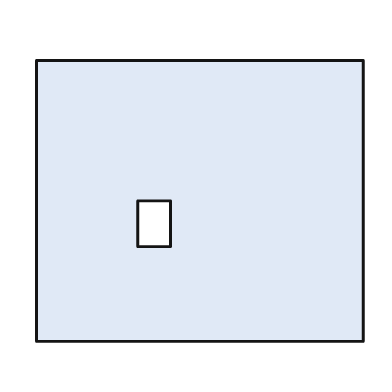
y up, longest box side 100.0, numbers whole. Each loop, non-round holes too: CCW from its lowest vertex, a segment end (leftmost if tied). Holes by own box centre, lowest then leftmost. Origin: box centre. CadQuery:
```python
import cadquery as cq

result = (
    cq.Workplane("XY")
    .moveTo(-50.0, -43.0)
    .lineTo(50.0, -43.0)
    .lineTo(50.0, 43.0)
    .lineTo(-50.0, 43.0)
    .close()
    .moveTo(-19.0, -14.0)
    .lineTo(-9.0, -14.0)
    .lineTo(-9.0, 0.0)
    .lineTo(-19.0, 0.0)
    .close()
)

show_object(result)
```